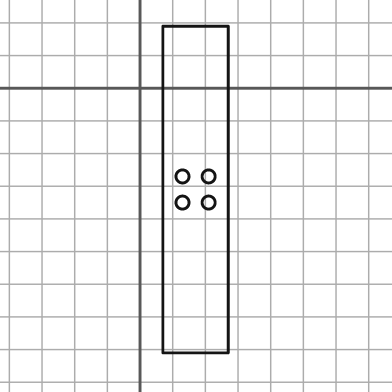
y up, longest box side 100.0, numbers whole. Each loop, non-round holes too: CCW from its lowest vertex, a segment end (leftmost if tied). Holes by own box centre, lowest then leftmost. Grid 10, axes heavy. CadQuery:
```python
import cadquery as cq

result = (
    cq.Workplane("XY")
    .moveTo(7.0, -81.0)
    .lineTo(27.0, -81.0)
    .lineTo(27.0, 19.0)
    .lineTo(7.0, 19.0)
    .close()
    .moveTo(13.0, -35.0)
    .circle(2.0)
    .moveTo(21.0, -35.0)
    .circle(2.0)
    .moveTo(13.0, -27.0)
    .circle(2.0)
    .moveTo(21.0, -27.0)
    .circle(2.0)
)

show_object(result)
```